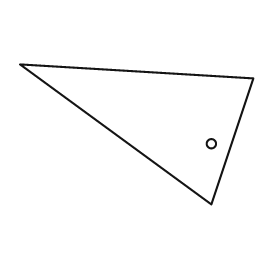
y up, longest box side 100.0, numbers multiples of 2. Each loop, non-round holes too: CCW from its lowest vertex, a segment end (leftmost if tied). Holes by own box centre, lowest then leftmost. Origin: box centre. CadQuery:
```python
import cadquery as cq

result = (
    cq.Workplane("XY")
    .moveTo(32.0, -30.0)
    .lineTo(50.0, 24.0)
    .lineTo(-50.0, 30.0)
    .close()
    .moveTo(32.0, -4.0)
    .circle(2.0)
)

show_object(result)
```